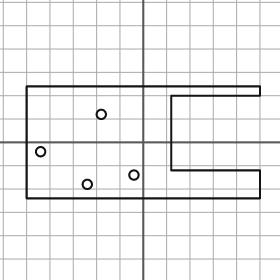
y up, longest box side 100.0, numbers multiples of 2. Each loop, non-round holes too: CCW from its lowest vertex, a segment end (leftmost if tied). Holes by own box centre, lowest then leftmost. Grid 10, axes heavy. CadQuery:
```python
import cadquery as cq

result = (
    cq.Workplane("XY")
    .moveTo(-50.0, -24.0)
    .lineTo(50.0, -24.0)
    .lineTo(50.0, -12.0)
    .lineTo(12.0, -12.0)
    .lineTo(12.0, 20.0)
    .lineTo(50.0, 20.0)
    .lineTo(50.0, 24.0)
    .lineTo(-50.0, 24.0)
    .close()
    .moveTo(-24.0, -18.0)
    .circle(2.0)
    .moveTo(-4.0, -14.0)
    .circle(2.0)
    .moveTo(-44.0, -4.0)
    .circle(2.0)
    .moveTo(-18.0, 12.0)
    .circle(2.0)
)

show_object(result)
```